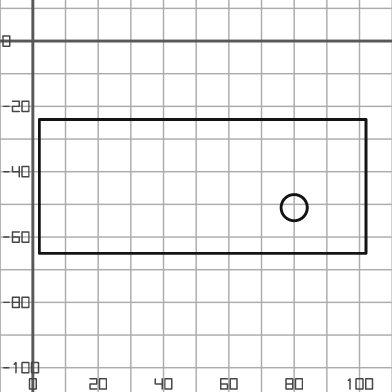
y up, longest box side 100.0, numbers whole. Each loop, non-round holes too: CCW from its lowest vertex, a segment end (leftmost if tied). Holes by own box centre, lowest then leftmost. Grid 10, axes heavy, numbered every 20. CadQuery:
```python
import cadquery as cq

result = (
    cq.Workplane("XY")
    .moveTo(2.0, -65.0)
    .lineTo(102.0, -65.0)
    .lineTo(102.0, -24.0)
    .lineTo(2.0, -24.0)
    .close()
    .moveTo(80.0, -51.0)
    .circle(4.0)
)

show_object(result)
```